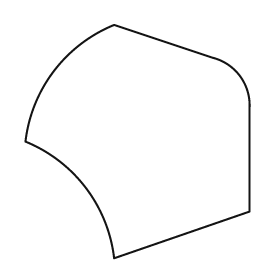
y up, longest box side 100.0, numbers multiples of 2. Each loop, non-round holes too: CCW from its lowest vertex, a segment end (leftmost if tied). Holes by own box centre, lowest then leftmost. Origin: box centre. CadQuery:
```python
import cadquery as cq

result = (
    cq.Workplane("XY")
    .moveTo(-10.0, -50.0)
    .lineTo(48.0, -30.0)
    .lineTo(48.0, 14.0)
    .threePointArc((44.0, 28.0), (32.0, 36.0))
    .lineTo(-10.0, 50.0)
    .threePointArc((-36.0, 30.0), (-48.0, 0.0))
    .threePointArc((-22.0, -20.0), (-10.0, -50.0))
    .close()
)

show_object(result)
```